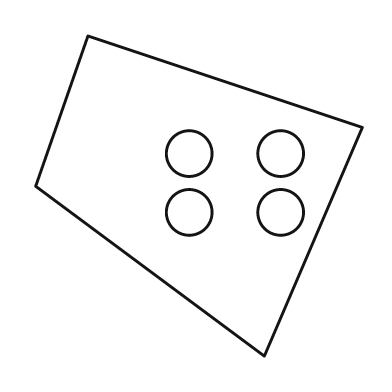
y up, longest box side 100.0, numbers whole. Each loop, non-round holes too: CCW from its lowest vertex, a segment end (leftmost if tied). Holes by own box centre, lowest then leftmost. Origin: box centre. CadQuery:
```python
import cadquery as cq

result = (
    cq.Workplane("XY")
    .moveTo(20.0, -49.0)
    .lineTo(50.0, 21.0)
    .lineTo(-34.0, 49.0)
    .lineTo(-50.0, 3.0)
    .close()
    .moveTo(-3.0, -5.0)
    .circle(7.0)
    .moveTo(25.0, -5.0)
    .circle(7.0)
    .moveTo(-3.0, 13.0)
    .circle(7.0)
    .moveTo(25.0, 13.0)
    .circle(7.0)
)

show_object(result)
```